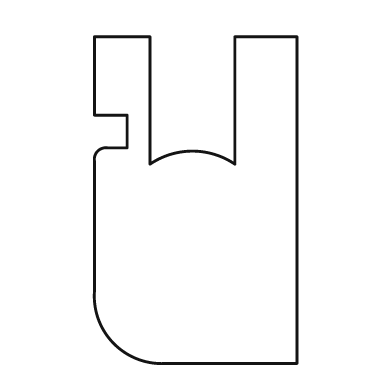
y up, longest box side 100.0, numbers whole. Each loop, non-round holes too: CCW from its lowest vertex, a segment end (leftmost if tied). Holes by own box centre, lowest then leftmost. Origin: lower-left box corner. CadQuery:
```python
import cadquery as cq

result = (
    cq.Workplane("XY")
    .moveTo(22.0, 0.0)
    .lineTo(62.0, 0.0)
    .lineTo(62.0, 100.0)
    .lineTo(43.0, 100.0)
    .lineTo(43.0, 61.0)
    .threePointArc((30.0, 65.0), (17.0, 61.0))
    .lineTo(17.0, 100.0)
    .lineTo(0.0, 100.0)
    .lineTo(0.0, 76.0)
    .lineTo(10.0, 76.0)
    .lineTo(10.0, 66.0)
    .lineTo(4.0, 66.0)
    .threePointArc((1.0, 65.0), (0.0, 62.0))
    .lineTo(0.0, 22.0)
    .threePointArc((6.0, 6.0), (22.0, 0.0))
    .close()
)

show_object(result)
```